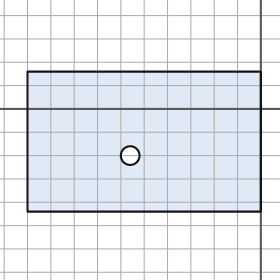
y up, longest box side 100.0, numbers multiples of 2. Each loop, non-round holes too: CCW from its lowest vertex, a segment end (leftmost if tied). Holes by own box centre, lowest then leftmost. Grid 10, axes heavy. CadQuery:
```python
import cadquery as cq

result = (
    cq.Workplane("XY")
    .moveTo(-100.0, -44.0)
    .lineTo(0.0, -44.0)
    .lineTo(0.0, 16.0)
    .lineTo(-100.0, 16.0)
    .close()
    .moveTo(-56.0, -20.0)
    .circle(4.0)
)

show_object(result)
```